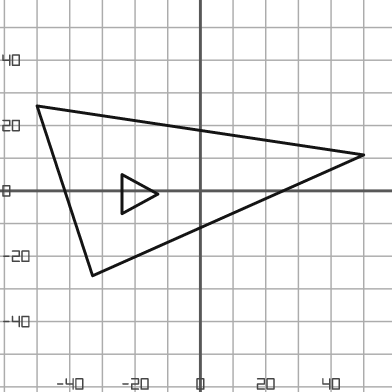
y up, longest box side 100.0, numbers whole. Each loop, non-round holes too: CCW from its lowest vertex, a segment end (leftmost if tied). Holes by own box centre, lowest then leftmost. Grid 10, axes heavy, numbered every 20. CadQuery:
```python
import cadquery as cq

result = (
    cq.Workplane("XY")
    .moveTo(-33.0, -26.0)
    .lineTo(50.0, 11.0)
    .lineTo(-50.0, 26.0)
    .close()
    .moveTo(-24.0, -7.0)
    .lineTo(-13.0, -1.0)
    .lineTo(-24.0, 5.0)
    .close()
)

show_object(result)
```